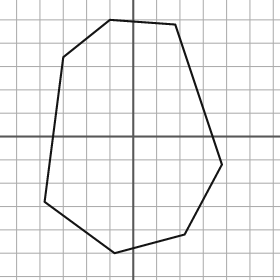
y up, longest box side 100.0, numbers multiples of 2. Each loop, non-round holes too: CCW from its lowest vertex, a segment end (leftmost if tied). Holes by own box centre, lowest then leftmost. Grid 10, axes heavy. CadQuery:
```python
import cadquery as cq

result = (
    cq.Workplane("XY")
    .moveTo(-8.0, -50.0)
    .lineTo(22.0, -42.0)
    .lineTo(38.0, -12.0)
    .lineTo(18.0, 48.0)
    .lineTo(-10.0, 50.0)
    .lineTo(-30.0, 34.0)
    .lineTo(-38.0, -28.0)
    .close()
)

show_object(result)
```